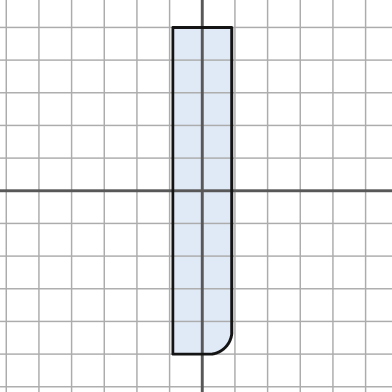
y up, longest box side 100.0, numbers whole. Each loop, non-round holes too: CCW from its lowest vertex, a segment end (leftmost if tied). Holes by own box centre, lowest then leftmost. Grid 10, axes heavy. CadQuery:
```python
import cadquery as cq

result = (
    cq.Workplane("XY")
    .moveTo(-9.0, -50.0)
    .lineTo(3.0, -50.0)
    .threePointArc((7.0, -48.0), (9.0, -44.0))
    .lineTo(9.0, 50.0)
    .lineTo(-9.0, 50.0)
    .close()
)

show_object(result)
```